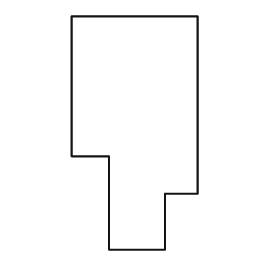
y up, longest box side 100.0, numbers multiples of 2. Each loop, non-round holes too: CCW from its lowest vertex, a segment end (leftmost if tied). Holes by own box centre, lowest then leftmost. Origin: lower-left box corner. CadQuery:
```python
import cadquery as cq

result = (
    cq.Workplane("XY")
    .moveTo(16.0, 0.0)
    .lineTo(40.0, 0.0)
    .lineTo(40.0, 24.0)
    .lineTo(54.0, 24.0)
    .lineTo(54.0, 100.0)
    .lineTo(0.0, 100.0)
    .lineTo(0.0, 40.0)
    .lineTo(16.0, 40.0)
    .close()
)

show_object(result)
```